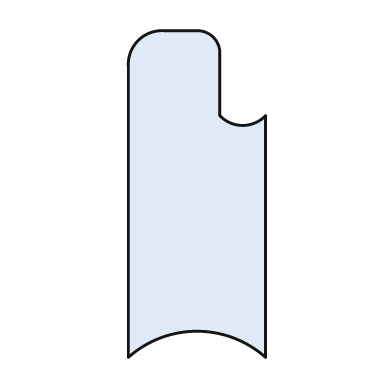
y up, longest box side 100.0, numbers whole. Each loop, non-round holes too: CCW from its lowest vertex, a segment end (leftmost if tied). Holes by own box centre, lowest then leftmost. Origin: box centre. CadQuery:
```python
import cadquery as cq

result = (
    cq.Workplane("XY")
    .moveTo(-21.0, -50.0)
    .threePointArc((0.0, -42.0), (21.0, -50.0))
    .lineTo(21.0, 24.0)
    .threePointArc((14.0, 21.0), (7.0, 24.0))
    .lineTo(7.0, 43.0)
    .threePointArc((5.0, 48.0), (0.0, 50.0))
    .lineTo(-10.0, 50.0)
    .threePointArc((-18.0, 47.0), (-21.0, 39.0))
    .close()
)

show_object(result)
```